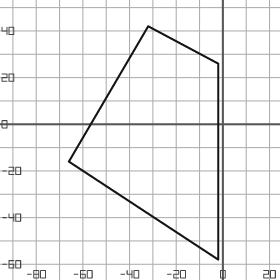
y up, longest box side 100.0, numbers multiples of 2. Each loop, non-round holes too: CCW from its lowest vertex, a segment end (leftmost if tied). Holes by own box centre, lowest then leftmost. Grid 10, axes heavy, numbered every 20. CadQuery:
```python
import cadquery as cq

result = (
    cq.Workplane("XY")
    .moveTo(-2.0, -58.0)
    .lineTo(-2.0, 26.0)
    .lineTo(-32.0, 42.0)
    .lineTo(-66.0, -16.0)
    .close()
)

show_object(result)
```